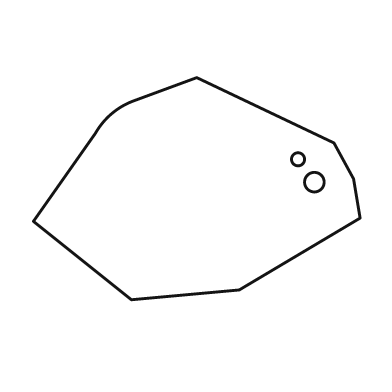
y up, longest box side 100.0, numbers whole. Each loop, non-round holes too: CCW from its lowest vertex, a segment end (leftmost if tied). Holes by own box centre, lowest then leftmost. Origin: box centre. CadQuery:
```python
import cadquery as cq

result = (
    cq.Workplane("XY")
    .moveTo(-20.0, -34.0)
    .lineTo(13.0, -31.0)
    .lineTo(50.0, -9.0)
    .lineTo(48.0, 3.0)
    .lineTo(42.0, 14.0)
    .lineTo(0.0, 34.0)
    .lineTo(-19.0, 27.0)
    .threePointArc((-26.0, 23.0), (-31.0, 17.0))
    .lineTo(-50.0, -10.0)
    .close()
    .moveTo(36.0, 2.0)
    .circle(3.0)
    .moveTo(31.0, 9.0)
    .circle(2.0)
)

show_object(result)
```